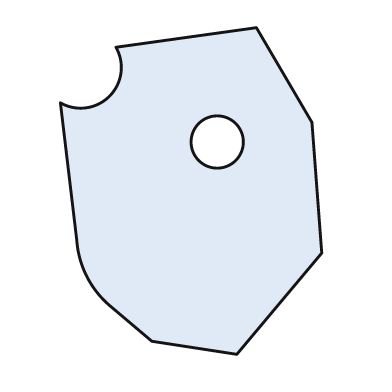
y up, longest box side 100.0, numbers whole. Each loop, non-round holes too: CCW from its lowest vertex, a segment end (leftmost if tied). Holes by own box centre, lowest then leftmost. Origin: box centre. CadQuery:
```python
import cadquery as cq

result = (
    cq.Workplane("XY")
    .moveTo(14.0, -50.0)
    .lineTo(40.0, -19.0)
    .lineTo(37.0, 21.0)
    .lineTo(20.0, 50.0)
    .lineTo(-23.0, 44.0)
    .threePointArc((-25.0, 29.0), (-40.0, 27.0))
    .lineTo(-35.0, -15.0)
    .threePointArc((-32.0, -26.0), (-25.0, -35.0))
    .lineTo(-12.0, -46.0)
    .close()
    .moveTo(8.0, 15.0)
    .circle(8.0)
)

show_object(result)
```